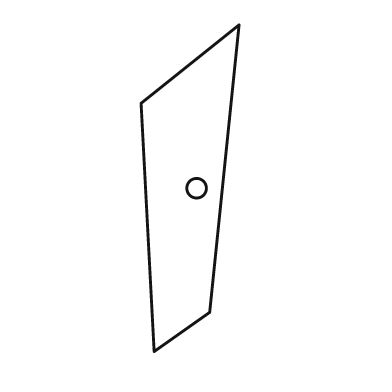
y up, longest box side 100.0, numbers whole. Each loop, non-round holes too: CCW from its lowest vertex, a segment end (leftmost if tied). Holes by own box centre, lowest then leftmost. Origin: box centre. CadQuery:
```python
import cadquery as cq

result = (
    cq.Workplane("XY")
    .moveTo(-11.0, -50.0)
    .lineTo(6.0, -38.0)
    .lineTo(15.0, 50.0)
    .lineTo(-15.0, 26.0)
    .close()
    .moveTo(2.0, 0.0)
    .circle(3.0)
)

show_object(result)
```